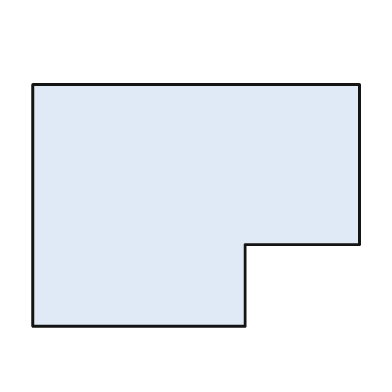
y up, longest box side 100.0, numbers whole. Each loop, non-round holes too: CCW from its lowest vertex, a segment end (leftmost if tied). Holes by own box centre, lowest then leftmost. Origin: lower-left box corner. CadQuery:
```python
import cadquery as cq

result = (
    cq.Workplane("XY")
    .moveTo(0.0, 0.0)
    .lineTo(65.0, 0.0)
    .lineTo(65.0, 25.0)
    .lineTo(100.0, 25.0)
    .lineTo(100.0, 74.0)
    .lineTo(0.0, 74.0)
    .close()
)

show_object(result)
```